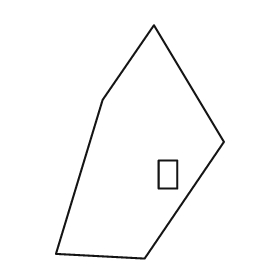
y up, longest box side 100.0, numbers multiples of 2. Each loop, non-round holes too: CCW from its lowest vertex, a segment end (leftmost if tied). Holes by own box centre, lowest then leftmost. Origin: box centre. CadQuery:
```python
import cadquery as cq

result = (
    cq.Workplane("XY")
    .moveTo(2.0, -50.0)
    .lineTo(36.0, 0.0)
    .lineTo(6.0, 50.0)
    .lineTo(-16.0, 18.0)
    .lineTo(-36.0, -48.0)
    .close()
    .moveTo(8.0, -20.0)
    .lineTo(16.0, -20.0)
    .lineTo(16.0, -8.0)
    .lineTo(8.0, -8.0)
    .close()
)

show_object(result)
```